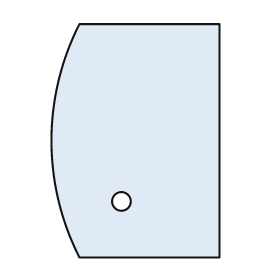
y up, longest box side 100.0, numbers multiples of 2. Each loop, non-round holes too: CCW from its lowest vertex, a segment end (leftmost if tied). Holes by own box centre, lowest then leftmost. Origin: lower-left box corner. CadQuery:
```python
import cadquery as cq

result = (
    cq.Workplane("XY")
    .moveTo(12.0, 0.0)
    .lineTo(72.0, 0.0)
    .lineTo(72.0, 100.0)
    .lineTo(12.0, 100.0)
    .threePointArc((0.0, 50.0), (12.0, 0.0))
    .close()
    .moveTo(30.0, 24.0)
    .circle(4.0)
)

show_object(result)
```